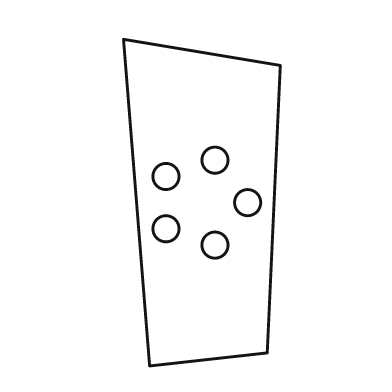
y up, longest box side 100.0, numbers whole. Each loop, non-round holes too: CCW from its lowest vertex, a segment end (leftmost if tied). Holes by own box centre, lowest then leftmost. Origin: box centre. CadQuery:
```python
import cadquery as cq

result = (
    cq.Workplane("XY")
    .moveTo(-16.0, -50.0)
    .lineTo(20.0, -46.0)
    .lineTo(24.0, 42.0)
    .lineTo(-24.0, 50.0)
    .close()
    .moveTo(4.0, -13.0)
    .circle(4.0)
    .moveTo(-11.0, -8.0)
    .circle(4.0)
    .moveTo(14.0, 0.0)
    .circle(4.0)
    .moveTo(-11.0, 8.0)
    .circle(4.0)
    .moveTo(4.0, 13.0)
    .circle(4.0)
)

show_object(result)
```